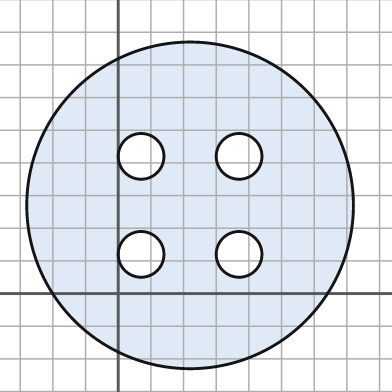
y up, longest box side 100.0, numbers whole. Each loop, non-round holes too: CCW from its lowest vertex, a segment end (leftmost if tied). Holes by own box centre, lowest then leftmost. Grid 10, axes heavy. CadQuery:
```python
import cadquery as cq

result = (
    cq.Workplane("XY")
    .moveTo(22.0, 27.0)
    .circle(50.0)
    .moveTo(7.0, 12.0)
    .circle(7.0)
    .moveTo(37.0, 12.0)
    .circle(7.0)
    .moveTo(7.0, 42.0)
    .circle(7.0)
    .moveTo(37.0, 42.0)
    .circle(7.0)
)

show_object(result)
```